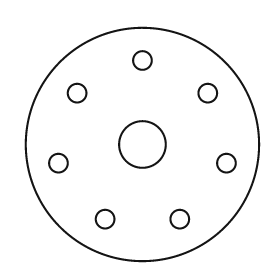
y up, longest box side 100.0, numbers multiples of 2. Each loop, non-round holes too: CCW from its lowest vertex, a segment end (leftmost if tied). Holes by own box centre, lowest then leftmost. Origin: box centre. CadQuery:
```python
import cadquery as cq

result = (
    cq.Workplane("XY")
    .moveTo(0.0, 0.0)
    .circle(50.0)
    .moveTo(-16.0, -32.0)
    .circle(4.0)
    .moveTo(16.0, -32.0)
    .circle(4.0)
    .moveTo(-36.0, -8.0)
    .circle(4.0)
    .moveTo(36.0, -8.0)
    .circle(4.0)
    .moveTo(0.0, 0.0)
    .circle(10.0)
    .moveTo(-28.0, 22.0)
    .circle(4.0)
    .moveTo(28.0, 22.0)
    .circle(4.0)
    .moveTo(0.0, 36.0)
    .circle(4.0)
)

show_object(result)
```